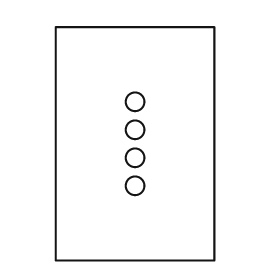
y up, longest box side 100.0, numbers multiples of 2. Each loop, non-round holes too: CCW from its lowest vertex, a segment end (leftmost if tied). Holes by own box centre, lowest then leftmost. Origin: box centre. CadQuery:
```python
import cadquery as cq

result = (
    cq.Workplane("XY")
    .moveTo(-34.0, -50.0)
    .lineTo(34.0, -50.0)
    .lineTo(34.0, 50.0)
    .lineTo(-34.0, 50.0)
    .close()
    .moveTo(0.0, -18.0)
    .circle(4.0)
    .moveTo(0.0, -6.0)
    .circle(4.0)
    .moveTo(0.0, 6.0)
    .circle(4.0)
    .moveTo(0.0, 18.0)
    .circle(4.0)
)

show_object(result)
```